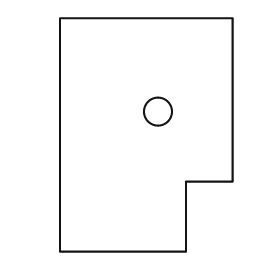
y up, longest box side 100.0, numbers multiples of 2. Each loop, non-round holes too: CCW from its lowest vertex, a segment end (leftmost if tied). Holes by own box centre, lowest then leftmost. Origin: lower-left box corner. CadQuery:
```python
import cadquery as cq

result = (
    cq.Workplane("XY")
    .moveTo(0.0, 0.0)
    .lineTo(54.0, 0.0)
    .lineTo(54.0, 30.0)
    .lineTo(74.0, 30.0)
    .lineTo(74.0, 100.0)
    .lineTo(0.0, 100.0)
    .close()
    .moveTo(42.0, 60.0)
    .circle(6.0)
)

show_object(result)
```